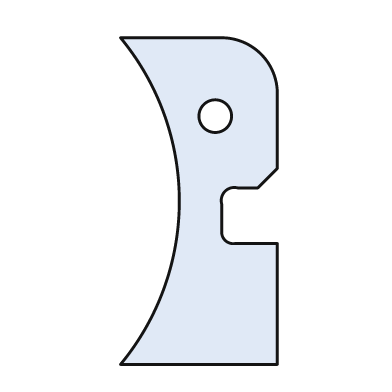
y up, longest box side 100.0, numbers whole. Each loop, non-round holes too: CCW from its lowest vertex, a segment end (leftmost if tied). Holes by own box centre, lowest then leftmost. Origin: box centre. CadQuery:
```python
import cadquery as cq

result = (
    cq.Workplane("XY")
    .moveTo(-24.0, -50.0)
    .lineTo(24.0, -50.0)
    .lineTo(24.0, -13.0)
    .lineTo(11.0, -13.0)
    .threePointArc((8.0, -12.0), (7.0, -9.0))
    .lineTo(7.0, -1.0)
    .threePointArc((8.0, 3.0), (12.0, 4.0))
    .lineTo(18.0, 4.0)
    .lineTo(24.0, 10.0)
    .lineTo(24.0, 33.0)
    .threePointArc((19.0, 45.0), (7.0, 50.0))
    .lineTo(-24.0, 50.0)
    .threePointArc((-6.0, 0.0), (-24.0, -50.0))
    .close()
    .moveTo(5.0, 26.0)
    .circle(5.0)
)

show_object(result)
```